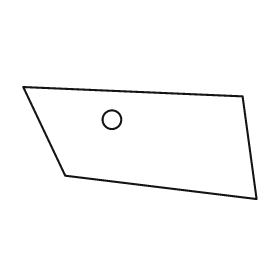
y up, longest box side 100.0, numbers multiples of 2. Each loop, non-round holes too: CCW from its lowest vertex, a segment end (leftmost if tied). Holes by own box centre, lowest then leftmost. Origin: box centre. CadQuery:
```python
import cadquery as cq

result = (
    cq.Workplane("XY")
    .moveTo(50.0, -24.0)
    .lineTo(44.0, 20.0)
    .lineTo(-50.0, 24.0)
    .lineTo(-32.0, -14.0)
    .close()
    .moveTo(-12.0, 10.0)
    .circle(4.0)
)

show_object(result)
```